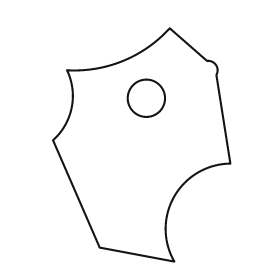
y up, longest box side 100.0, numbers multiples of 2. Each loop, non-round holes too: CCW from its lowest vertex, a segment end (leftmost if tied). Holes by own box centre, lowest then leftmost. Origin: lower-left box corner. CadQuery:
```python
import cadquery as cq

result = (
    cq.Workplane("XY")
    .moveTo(52.0, 0.0)
    .threePointArc((52.0, 28.0), (76.0, 42.0))
    .lineTo(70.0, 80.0)
    .threePointArc((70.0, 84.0), (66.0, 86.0))
    .lineTo(50.0, 100.0)
    .threePointArc((30.0, 86.0), (6.0, 82.0))
    .threePointArc((8.0, 66.0), (0.0, 52.0))
    .lineTo(20.0, 6.0)
    .close()
    .moveTo(40.0, 70.0)
    .circle(8.0)
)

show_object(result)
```